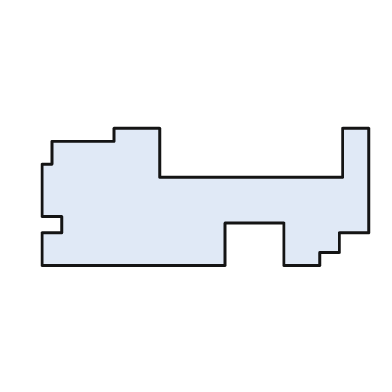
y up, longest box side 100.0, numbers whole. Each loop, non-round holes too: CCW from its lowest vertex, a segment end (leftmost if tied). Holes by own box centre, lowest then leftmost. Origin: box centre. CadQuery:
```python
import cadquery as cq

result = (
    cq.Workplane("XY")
    .moveTo(-50.0, -21.0)
    .lineTo(6.0, -21.0)
    .lineTo(6.0, -8.0)
    .lineTo(24.0, -8.0)
    .lineTo(24.0, -21.0)
    .lineTo(35.0, -21.0)
    .lineTo(35.0, -17.0)
    .lineTo(41.0, -17.0)
    .lineTo(41.0, -11.0)
    .lineTo(50.0, -11.0)
    .lineTo(50.0, 21.0)
    .lineTo(42.0, 21.0)
    .lineTo(42.0, 6.0)
    .lineTo(-14.0, 6.0)
    .lineTo(-14.0, 21.0)
    .lineTo(-28.0, 21.0)
    .lineTo(-28.0, 17.0)
    .lineTo(-47.0, 17.0)
    .lineTo(-47.0, 10.0)
    .lineTo(-50.0, 10.0)
    .lineTo(-50.0, -6.0)
    .lineTo(-44.0, -6.0)
    .lineTo(-44.0, -11.0)
    .lineTo(-50.0, -11.0)
    .close()
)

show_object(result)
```